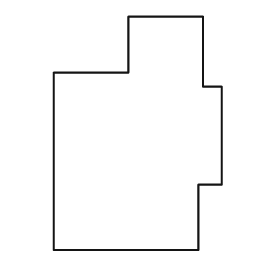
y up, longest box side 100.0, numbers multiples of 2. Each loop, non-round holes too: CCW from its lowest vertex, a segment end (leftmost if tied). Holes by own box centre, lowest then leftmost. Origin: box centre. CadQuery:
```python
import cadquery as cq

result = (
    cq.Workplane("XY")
    .moveTo(-36.0, -50.0)
    .lineTo(26.0, -50.0)
    .lineTo(26.0, -22.0)
    .lineTo(36.0, -22.0)
    .lineTo(36.0, 20.0)
    .lineTo(28.0, 20.0)
    .lineTo(28.0, 50.0)
    .lineTo(-4.0, 50.0)
    .lineTo(-4.0, 26.0)
    .lineTo(-36.0, 26.0)
    .close()
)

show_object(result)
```